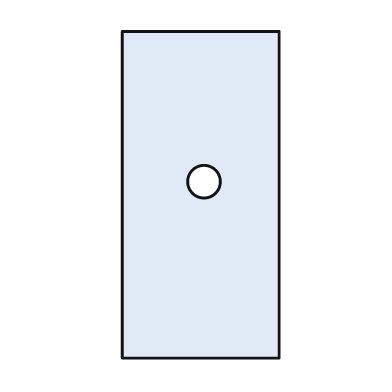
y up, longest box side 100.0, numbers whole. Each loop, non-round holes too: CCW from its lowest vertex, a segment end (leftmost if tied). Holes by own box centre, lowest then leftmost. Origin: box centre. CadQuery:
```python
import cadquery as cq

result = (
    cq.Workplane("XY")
    .moveTo(-24.0, -50.0)
    .lineTo(24.0, -50.0)
    .lineTo(24.0, 50.0)
    .lineTo(-24.0, 50.0)
    .close()
    .moveTo(1.0, 4.0)
    .circle(5.0)
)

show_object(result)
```